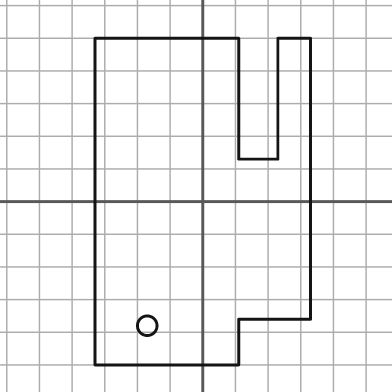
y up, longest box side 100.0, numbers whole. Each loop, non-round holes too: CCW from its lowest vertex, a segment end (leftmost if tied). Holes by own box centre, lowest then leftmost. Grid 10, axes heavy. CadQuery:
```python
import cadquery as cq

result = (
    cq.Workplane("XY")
    .moveTo(-33.0, -50.0)
    .lineTo(11.0, -50.0)
    .lineTo(11.0, -36.0)
    .lineTo(33.0, -36.0)
    .lineTo(33.0, 50.0)
    .lineTo(23.0, 50.0)
    .lineTo(23.0, 13.0)
    .lineTo(11.0, 13.0)
    .lineTo(11.0, 50.0)
    .lineTo(-33.0, 50.0)
    .close()
    .moveTo(-17.0, -38.0)
    .circle(3.0)
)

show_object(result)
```